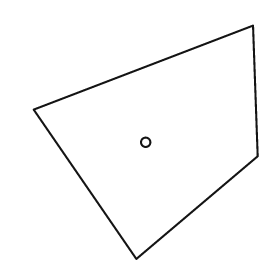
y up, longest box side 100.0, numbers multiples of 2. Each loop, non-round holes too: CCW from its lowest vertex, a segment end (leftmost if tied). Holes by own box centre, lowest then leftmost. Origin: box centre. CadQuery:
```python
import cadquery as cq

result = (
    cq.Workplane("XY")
    .moveTo(-4.0, -50.0)
    .lineTo(48.0, -6.0)
    .lineTo(46.0, 50.0)
    .lineTo(-48.0, 14.0)
    .close()
    .moveTo(0.0, 0.0)
    .circle(2.0)
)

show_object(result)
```